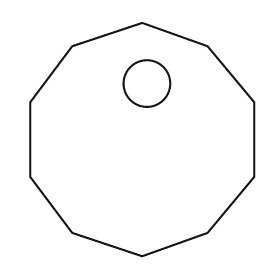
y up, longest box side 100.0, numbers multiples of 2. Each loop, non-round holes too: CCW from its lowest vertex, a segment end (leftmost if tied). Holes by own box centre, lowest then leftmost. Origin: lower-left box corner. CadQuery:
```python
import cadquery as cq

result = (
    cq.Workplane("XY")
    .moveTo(48.0, 0.0)
    .lineTo(76.0, 10.0)
    .lineTo(96.0, 34.0)
    .lineTo(96.0, 66.0)
    .lineTo(76.0, 90.0)
    .lineTo(48.0, 100.0)
    .lineTo(18.0, 90.0)
    .lineTo(0.0, 66.0)
    .lineTo(0.0, 34.0)
    .lineTo(18.0, 10.0)
    .close()
    .moveTo(50.0, 74.0)
    .circle(10.0)
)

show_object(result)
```